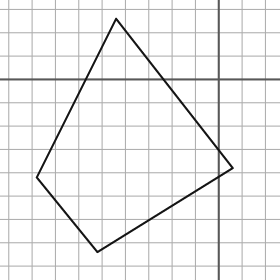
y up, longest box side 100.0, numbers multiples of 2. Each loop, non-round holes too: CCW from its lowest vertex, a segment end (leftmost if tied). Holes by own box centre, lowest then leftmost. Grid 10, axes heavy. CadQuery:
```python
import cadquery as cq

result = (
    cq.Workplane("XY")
    .moveTo(-52.0, -74.0)
    .lineTo(6.0, -38.0)
    .lineTo(-44.0, 26.0)
    .lineTo(-78.0, -42.0)
    .close()
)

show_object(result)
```